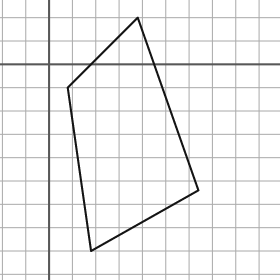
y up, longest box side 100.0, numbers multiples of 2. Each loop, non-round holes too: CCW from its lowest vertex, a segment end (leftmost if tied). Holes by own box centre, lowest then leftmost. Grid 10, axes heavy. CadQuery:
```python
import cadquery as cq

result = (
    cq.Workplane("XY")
    .moveTo(18.0, -80.0)
    .lineTo(64.0, -54.0)
    .lineTo(38.0, 20.0)
    .lineTo(8.0, -10.0)
    .close()
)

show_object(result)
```